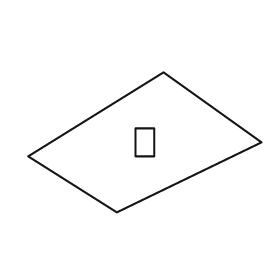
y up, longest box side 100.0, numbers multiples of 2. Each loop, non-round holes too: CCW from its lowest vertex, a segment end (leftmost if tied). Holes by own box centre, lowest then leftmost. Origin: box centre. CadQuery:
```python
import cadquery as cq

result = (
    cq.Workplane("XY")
    .moveTo(-12.0, -30.0)
    .lineTo(50.0, 0.0)
    .lineTo(8.0, 30.0)
    .lineTo(-50.0, -6.0)
    .close()
    .moveTo(-4.0, -6.0)
    .lineTo(4.0, -6.0)
    .lineTo(4.0, 6.0)
    .lineTo(-4.0, 6.0)
    .close()
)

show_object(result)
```